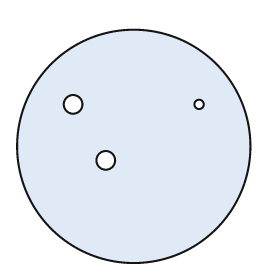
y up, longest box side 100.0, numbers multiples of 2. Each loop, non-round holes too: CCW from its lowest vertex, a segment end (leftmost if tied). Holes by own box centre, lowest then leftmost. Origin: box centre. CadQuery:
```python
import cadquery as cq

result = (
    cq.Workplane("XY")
    .moveTo(0.0, 0.0)
    .circle(50.0)
    .moveTo(-12.0, -6.0)
    .circle(4.0)
    .moveTo(-26.0, 18.0)
    .circle(4.0)
    .moveTo(28.0, 18.0)
    .circle(2.0)
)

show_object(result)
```